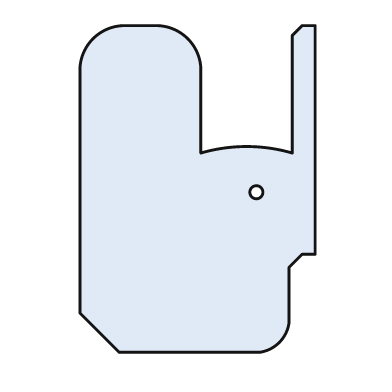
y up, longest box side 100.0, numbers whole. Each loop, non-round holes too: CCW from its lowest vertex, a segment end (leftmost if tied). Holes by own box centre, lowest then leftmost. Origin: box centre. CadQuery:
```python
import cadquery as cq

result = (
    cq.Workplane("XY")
    .moveTo(-24.0, -50.0)
    .lineTo(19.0, -50.0)
    .threePointArc((25.0, -47.0), (28.0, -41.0))
    .lineTo(28.0, -24.0)
    .lineTo(32.0, -20.0)
    .lineTo(36.0, -20.0)
    .lineTo(36.0, 50.0)
    .lineTo(32.0, 50.0)
    .lineTo(29.0, 47.0)
    .lineTo(29.0, 11.0)
    .threePointArc((15.0, 13.0), (1.0, 11.0))
    .lineTo(1.0, 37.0)
    .threePointArc((-3.0, 46.0), (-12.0, 50.0))
    .lineTo(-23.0, 50.0)
    .threePointArc((-32.0, 46.0), (-36.0, 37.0))
    .lineTo(-36.0, -38.0)
    .close()
    .moveTo(18.0, -1.0)
    .circle(2.0)
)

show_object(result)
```